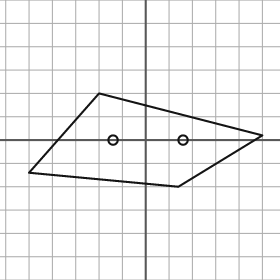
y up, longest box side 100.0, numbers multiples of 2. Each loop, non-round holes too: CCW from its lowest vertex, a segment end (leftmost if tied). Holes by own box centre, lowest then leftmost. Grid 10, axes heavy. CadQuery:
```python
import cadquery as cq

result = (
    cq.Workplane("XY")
    .moveTo(14.0, -20.0)
    .lineTo(50.0, 2.0)
    .lineTo(-20.0, 20.0)
    .lineTo(-50.0, -14.0)
    .close()
    .moveTo(-14.0, 0.0)
    .circle(2.0)
    .moveTo(16.0, 0.0)
    .circle(2.0)
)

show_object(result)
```